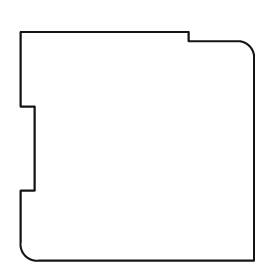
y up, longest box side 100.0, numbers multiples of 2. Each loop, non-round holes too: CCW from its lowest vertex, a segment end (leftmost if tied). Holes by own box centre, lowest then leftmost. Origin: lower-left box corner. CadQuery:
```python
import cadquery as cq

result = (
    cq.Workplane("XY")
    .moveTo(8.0, 0.0)
    .lineTo(100.0, 0.0)
    .lineTo(100.0, 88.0)
    .threePointArc((98.0, 92.0), (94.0, 94.0))
    .lineTo(72.0, 94.0)
    .lineTo(72.0, 98.0)
    .lineTo(0.0, 98.0)
    .lineTo(0.0, 66.0)
    .lineTo(6.0, 66.0)
    .lineTo(6.0, 30.0)
    .lineTo(0.0, 30.0)
    .lineTo(0.0, 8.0)
    .threePointArc((2.0, 2.0), (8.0, 0.0))
    .close()
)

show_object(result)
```